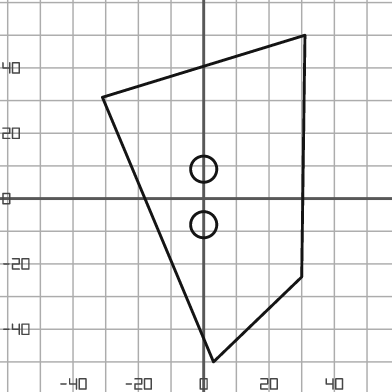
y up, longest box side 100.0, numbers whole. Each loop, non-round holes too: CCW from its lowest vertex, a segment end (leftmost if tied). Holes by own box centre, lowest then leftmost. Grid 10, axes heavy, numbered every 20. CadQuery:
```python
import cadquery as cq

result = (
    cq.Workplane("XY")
    .moveTo(3.0, -50.0)
    .lineTo(30.0, -24.0)
    .lineTo(31.0, 50.0)
    .lineTo(-31.0, 31.0)
    .close()
    .moveTo(0.0, -8.0)
    .circle(4.0)
    .moveTo(0.0, 9.0)
    .circle(4.0)
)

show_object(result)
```